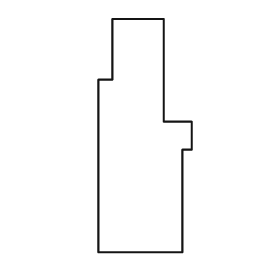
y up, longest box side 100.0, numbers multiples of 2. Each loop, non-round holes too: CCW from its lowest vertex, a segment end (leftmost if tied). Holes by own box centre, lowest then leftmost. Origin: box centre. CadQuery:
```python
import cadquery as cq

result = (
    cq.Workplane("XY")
    .moveTo(-20.0, -50.0)
    .lineTo(16.0, -50.0)
    .lineTo(16.0, -6.0)
    .lineTo(20.0, -6.0)
    .lineTo(20.0, 6.0)
    .lineTo(8.0, 6.0)
    .lineTo(8.0, 50.0)
    .lineTo(-14.0, 50.0)
    .lineTo(-14.0, 24.0)
    .lineTo(-20.0, 24.0)
    .close()
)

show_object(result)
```